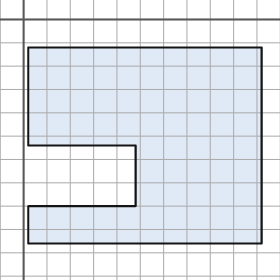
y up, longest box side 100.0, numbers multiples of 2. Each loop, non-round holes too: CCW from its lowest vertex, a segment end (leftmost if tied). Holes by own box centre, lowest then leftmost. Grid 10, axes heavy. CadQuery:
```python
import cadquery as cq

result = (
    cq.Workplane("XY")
    .moveTo(2.0, -96.0)
    .lineTo(102.0, -96.0)
    .lineTo(102.0, -12.0)
    .lineTo(2.0, -12.0)
    .lineTo(2.0, -54.0)
    .lineTo(48.0, -54.0)
    .lineTo(48.0, -80.0)
    .lineTo(2.0, -80.0)
    .close()
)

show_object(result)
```